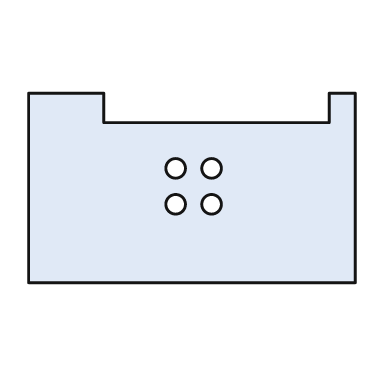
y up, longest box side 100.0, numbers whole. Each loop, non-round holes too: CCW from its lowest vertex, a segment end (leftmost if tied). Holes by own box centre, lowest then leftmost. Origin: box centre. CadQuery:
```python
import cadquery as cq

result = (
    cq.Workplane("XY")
    .moveTo(-50.0, -29.0)
    .lineTo(50.0, -29.0)
    .lineTo(50.0, 29.0)
    .lineTo(42.0, 29.0)
    .lineTo(42.0, 20.0)
    .lineTo(-27.0, 20.0)
    .lineTo(-27.0, 29.0)
    .lineTo(-50.0, 29.0)
    .close()
    .moveTo(-5.0, -5.0)
    .circle(3.0)
    .moveTo(6.0, -5.0)
    .circle(3.0)
    .moveTo(-5.0, 6.0)
    .circle(3.0)
    .moveTo(6.0, 6.0)
    .circle(3.0)
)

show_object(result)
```